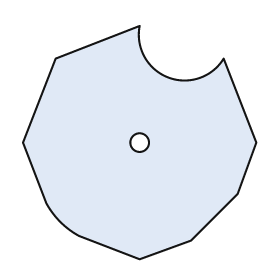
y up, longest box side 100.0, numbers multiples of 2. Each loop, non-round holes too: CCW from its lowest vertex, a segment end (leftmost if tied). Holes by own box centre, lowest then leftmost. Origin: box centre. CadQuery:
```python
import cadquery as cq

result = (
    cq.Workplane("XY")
    .moveTo(0.0, -50.0)
    .lineTo(22.0, -42.0)
    .lineTo(42.0, -22.0)
    .lineTo(50.0, 0.0)
    .lineTo(36.0, 36.0)
    .threePointArc((12.0, 28.0), (0.0, 50.0))
    .lineTo(-36.0, 36.0)
    .lineTo(-50.0, 0.0)
    .lineTo(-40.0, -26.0)
    .threePointArc((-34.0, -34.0), (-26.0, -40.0))
    .close()
    .moveTo(0.0, 0.0)
    .circle(4.0)
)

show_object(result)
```